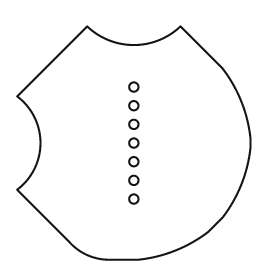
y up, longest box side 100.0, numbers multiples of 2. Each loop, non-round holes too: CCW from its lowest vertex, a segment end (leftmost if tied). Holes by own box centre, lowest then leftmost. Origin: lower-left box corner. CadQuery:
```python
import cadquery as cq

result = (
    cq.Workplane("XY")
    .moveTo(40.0, 0.0)
    .lineTo(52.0, 0.0)
    .threePointArc((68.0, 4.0), (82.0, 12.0))
    .lineTo(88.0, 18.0)
    .threePointArc((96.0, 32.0), (100.0, 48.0))
    .lineTo(100.0, 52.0)
    .threePointArc((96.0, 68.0), (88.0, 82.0))
    .lineTo(70.0, 100.0)
    .threePointArc((50.0, 92.0), (30.0, 100.0))
    .lineTo(0.0, 70.0)
    .threePointArc((10.0, 50.0), (0.0, 30.0))
    .lineTo(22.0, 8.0)
    .threePointArc((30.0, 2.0), (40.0, 0.0))
    .close()
    .moveTo(50.0, 26.0)
    .circle(2.0)
    .moveTo(50.0, 34.0)
    .circle(2.0)
    .moveTo(50.0, 42.0)
    .circle(2.0)
    .moveTo(50.0, 50.0)
    .circle(2.0)
    .moveTo(50.0, 58.0)
    .circle(2.0)
    .moveTo(50.0, 66.0)
    .circle(2.0)
    .moveTo(50.0, 74.0)
    .circle(2.0)
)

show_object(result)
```